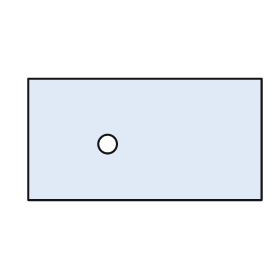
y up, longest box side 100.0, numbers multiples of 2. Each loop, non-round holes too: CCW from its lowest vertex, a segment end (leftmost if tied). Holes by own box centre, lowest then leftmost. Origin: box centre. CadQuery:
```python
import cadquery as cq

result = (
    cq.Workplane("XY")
    .moveTo(-50.0, -26.0)
    .lineTo(50.0, -26.0)
    .lineTo(50.0, 26.0)
    .lineTo(-50.0, 26.0)
    .close()
    .moveTo(-16.0, -2.0)
    .circle(4.0)
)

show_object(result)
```